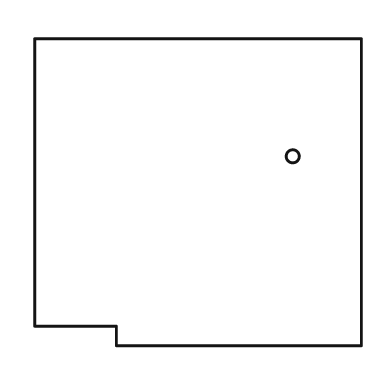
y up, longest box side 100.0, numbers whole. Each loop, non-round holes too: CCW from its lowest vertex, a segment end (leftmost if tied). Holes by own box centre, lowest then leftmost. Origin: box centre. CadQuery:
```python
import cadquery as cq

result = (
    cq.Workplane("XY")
    .moveTo(-25.0, -47.0)
    .lineTo(50.0, -47.0)
    .lineTo(50.0, 47.0)
    .lineTo(-50.0, 47.0)
    .lineTo(-50.0, -41.0)
    .lineTo(-25.0, -41.0)
    .close()
    .moveTo(29.0, 11.0)
    .circle(2.0)
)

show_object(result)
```